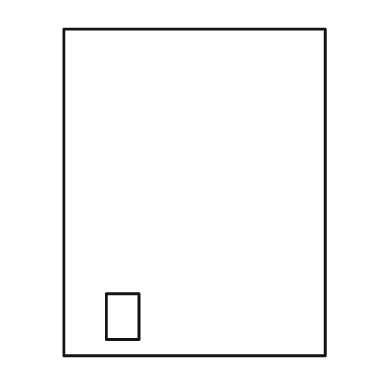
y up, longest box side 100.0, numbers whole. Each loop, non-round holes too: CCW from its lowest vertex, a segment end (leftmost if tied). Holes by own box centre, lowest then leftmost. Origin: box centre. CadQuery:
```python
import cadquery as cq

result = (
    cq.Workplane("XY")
    .moveTo(-40.0, -50.0)
    .lineTo(40.0, -50.0)
    .lineTo(40.0, 50.0)
    .lineTo(-40.0, 50.0)
    .close()
    .moveTo(-27.0, -45.0)
    .lineTo(-17.0, -45.0)
    .lineTo(-17.0, -31.0)
    .lineTo(-27.0, -31.0)
    .close()
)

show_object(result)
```